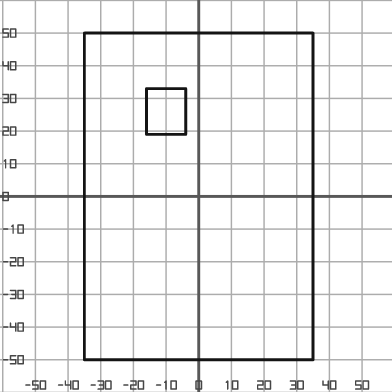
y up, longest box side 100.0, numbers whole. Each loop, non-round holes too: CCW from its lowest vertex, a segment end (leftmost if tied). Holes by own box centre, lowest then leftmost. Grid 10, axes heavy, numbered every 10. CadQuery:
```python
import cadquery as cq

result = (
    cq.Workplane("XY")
    .moveTo(-35.0, -50.0)
    .lineTo(35.0, -50.0)
    .lineTo(35.0, 50.0)
    .lineTo(-35.0, 50.0)
    .close()
    .moveTo(-16.0, 19.0)
    .lineTo(-4.0, 19.0)
    .lineTo(-4.0, 33.0)
    .lineTo(-16.0, 33.0)
    .close()
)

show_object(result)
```